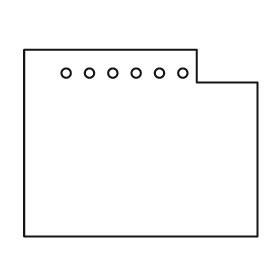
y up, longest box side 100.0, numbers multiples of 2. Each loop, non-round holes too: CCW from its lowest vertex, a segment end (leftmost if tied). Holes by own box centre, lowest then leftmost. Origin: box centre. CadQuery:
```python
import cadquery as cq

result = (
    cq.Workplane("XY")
    .moveTo(-50.0, -40.0)
    .lineTo(50.0, -40.0)
    .lineTo(50.0, 26.0)
    .lineTo(24.0, 26.0)
    .lineTo(24.0, 40.0)
    .lineTo(-50.0, 40.0)
    .close()
    .moveTo(-32.0, 30.0)
    .circle(2.0)
    .moveTo(-22.0, 30.0)
    .circle(2.0)
    .moveTo(-12.0, 30.0)
    .circle(2.0)
    .moveTo(-2.0, 30.0)
    .circle(2.0)
    .moveTo(8.0, 30.0)
    .circle(2.0)
    .moveTo(18.0, 30.0)
    .circle(2.0)
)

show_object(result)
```